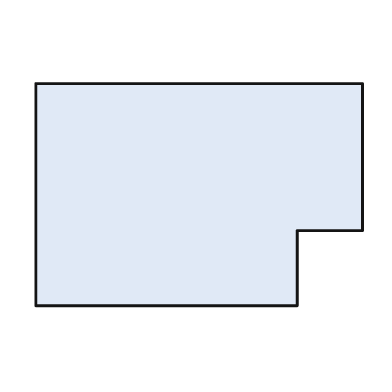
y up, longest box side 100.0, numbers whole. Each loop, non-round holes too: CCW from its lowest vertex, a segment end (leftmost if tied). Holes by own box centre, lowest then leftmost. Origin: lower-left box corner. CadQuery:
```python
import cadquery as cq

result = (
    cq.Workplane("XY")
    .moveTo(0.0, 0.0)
    .lineTo(80.0, 0.0)
    .lineTo(80.0, 23.0)
    .lineTo(100.0, 23.0)
    .lineTo(100.0, 68.0)
    .lineTo(0.0, 68.0)
    .close()
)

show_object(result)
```